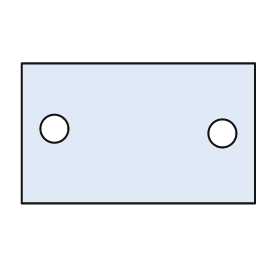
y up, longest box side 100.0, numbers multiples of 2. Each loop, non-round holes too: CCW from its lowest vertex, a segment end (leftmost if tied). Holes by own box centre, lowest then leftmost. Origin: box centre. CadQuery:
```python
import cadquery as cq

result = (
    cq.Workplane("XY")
    .moveTo(-50.0, -30.0)
    .lineTo(50.0, -30.0)
    .lineTo(50.0, 30.0)
    .lineTo(-50.0, 30.0)
    .close()
    .moveTo(36.0, 0.0)
    .circle(6.0)
    .moveTo(-36.0, 2.0)
    .circle(6.0)
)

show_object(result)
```